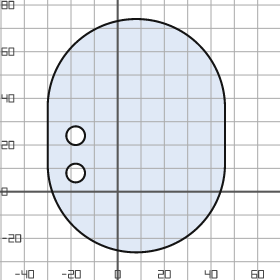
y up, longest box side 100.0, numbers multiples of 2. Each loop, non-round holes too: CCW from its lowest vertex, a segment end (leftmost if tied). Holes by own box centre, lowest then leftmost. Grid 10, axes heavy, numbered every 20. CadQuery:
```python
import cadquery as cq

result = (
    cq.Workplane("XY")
    .moveTo(-30.0, 12.0)
    .threePointArc((8.0, -26.0), (46.0, 12.0))
    .lineTo(46.0, 36.0)
    .threePointArc((8.0, 74.0), (-30.0, 36.0))
    .close()
    .moveTo(-18.0, 8.0)
    .circle(4.0)
    .moveTo(-18.0, 24.0)
    .circle(4.0)
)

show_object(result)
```